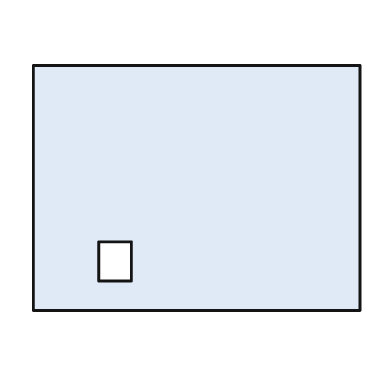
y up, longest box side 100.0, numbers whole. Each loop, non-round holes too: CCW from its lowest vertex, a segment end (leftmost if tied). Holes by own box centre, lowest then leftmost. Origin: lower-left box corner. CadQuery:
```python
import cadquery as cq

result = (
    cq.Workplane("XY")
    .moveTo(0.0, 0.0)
    .lineTo(100.0, 0.0)
    .lineTo(100.0, 75.0)
    .lineTo(0.0, 75.0)
    .close()
    .moveTo(20.0, 9.0)
    .lineTo(30.0, 9.0)
    .lineTo(30.0, 21.0)
    .lineTo(20.0, 21.0)
    .close()
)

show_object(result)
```